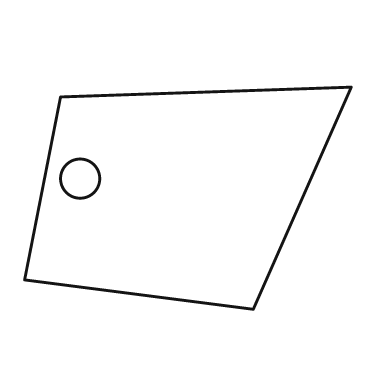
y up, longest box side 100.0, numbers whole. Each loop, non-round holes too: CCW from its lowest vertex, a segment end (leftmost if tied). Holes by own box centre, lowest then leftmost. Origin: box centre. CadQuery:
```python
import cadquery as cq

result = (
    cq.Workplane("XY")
    .moveTo(20.0, -34.0)
    .lineTo(50.0, 34.0)
    .lineTo(-39.0, 31.0)
    .lineTo(-50.0, -25.0)
    .close()
    .moveTo(-33.0, 6.0)
    .circle(6.0)
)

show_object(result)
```